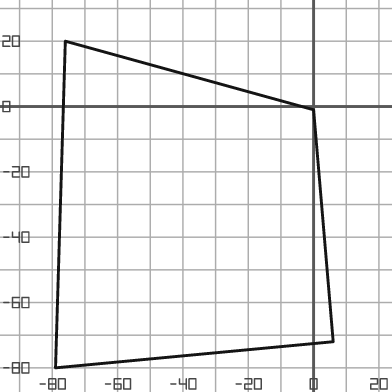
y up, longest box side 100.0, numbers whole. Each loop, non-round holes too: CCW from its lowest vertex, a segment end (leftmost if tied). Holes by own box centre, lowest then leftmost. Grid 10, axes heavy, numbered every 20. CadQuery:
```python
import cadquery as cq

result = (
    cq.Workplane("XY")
    .moveTo(-79.0, -80.0)
    .lineTo(6.0, -72.0)
    .lineTo(0.0, -1.0)
    .lineTo(-76.0, 20.0)
    .close()
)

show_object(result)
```